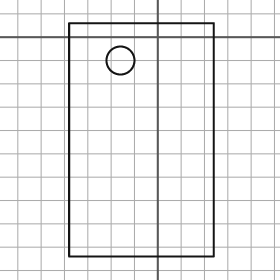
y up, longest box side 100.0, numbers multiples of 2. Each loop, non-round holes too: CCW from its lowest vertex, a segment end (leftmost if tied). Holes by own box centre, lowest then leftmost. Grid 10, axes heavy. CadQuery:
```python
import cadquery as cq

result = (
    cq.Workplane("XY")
    .moveTo(-38.0, -94.0)
    .lineTo(24.0, -94.0)
    .lineTo(24.0, 6.0)
    .lineTo(-38.0, 6.0)
    .close()
    .moveTo(-16.0, -10.0)
    .circle(6.0)
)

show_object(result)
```